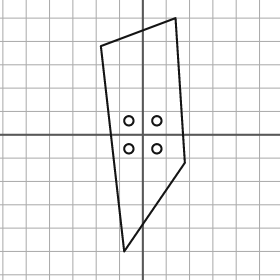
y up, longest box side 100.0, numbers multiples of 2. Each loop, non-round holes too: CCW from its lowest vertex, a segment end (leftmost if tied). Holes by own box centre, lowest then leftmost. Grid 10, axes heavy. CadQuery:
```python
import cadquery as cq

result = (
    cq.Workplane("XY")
    .moveTo(-8.0, -50.0)
    .lineTo(18.0, -12.0)
    .lineTo(14.0, 50.0)
    .lineTo(-18.0, 38.0)
    .close()
    .moveTo(-6.0, -6.0)
    .circle(2.0)
    .moveTo(6.0, -6.0)
    .circle(2.0)
    .moveTo(-6.0, 6.0)
    .circle(2.0)
    .moveTo(6.0, 6.0)
    .circle(2.0)
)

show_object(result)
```